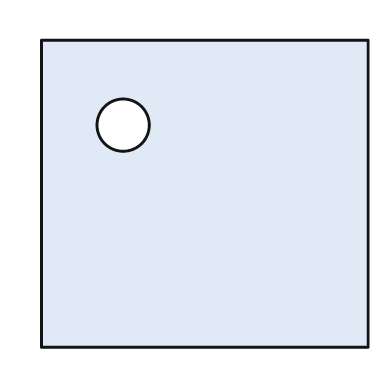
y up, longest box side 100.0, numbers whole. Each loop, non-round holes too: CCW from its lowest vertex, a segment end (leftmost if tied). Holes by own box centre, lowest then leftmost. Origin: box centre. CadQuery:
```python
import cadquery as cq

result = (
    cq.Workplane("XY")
    .moveTo(-50.0, -47.0)
    .lineTo(50.0, -47.0)
    .lineTo(50.0, 47.0)
    .lineTo(-50.0, 47.0)
    .close()
    .moveTo(-25.0, 21.0)
    .circle(8.0)
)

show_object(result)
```